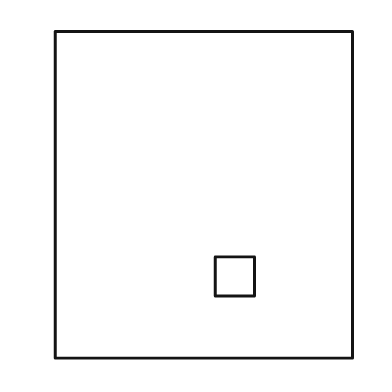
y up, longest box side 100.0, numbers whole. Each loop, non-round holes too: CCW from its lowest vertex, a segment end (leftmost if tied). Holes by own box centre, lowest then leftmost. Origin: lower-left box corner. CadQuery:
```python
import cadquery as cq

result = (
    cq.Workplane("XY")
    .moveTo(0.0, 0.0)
    .lineTo(91.0, 0.0)
    .lineTo(91.0, 100.0)
    .lineTo(0.0, 100.0)
    .close()
    .moveTo(49.0, 19.0)
    .lineTo(61.0, 19.0)
    .lineTo(61.0, 31.0)
    .lineTo(49.0, 31.0)
    .close()
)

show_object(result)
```